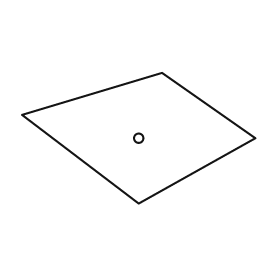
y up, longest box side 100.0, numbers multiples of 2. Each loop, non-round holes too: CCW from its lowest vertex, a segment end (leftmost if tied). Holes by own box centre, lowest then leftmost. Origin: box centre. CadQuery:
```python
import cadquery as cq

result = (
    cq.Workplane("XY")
    .moveTo(0.0, -28.0)
    .lineTo(50.0, 0.0)
    .lineTo(10.0, 28.0)
    .lineTo(-50.0, 10.0)
    .close()
    .moveTo(0.0, 0.0)
    .circle(2.0)
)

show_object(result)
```